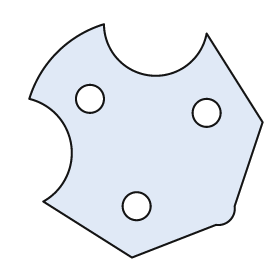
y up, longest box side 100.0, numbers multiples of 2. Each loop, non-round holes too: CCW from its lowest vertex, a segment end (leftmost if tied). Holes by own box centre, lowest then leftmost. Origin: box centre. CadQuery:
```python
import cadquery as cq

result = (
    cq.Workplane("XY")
    .moveTo(-6.0, -50.0)
    .lineTo(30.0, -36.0)
    .threePointArc((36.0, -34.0), (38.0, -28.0))
    .lineTo(50.0, 8.0)
    .lineTo(26.0, 46.0)
    .threePointArc((2.0, 28.0), (-18.0, 50.0))
    .threePointArc((-38.0, 38.0), (-50.0, 18.0))
    .threePointArc((-32.0, -2.0), (-44.0, -26.0))
    .close()
    .moveTo(-4.0, -28.0)
    .circle(6.0)
    .moveTo(26.0, 12.0)
    .circle(6.0)
    .moveTo(-24.0, 18.0)
    .circle(6.0)
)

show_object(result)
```